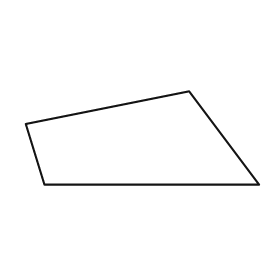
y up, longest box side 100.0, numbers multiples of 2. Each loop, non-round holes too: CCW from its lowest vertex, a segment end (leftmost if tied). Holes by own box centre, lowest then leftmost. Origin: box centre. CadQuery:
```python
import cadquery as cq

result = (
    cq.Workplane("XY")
    .moveTo(-42.0, -20.0)
    .lineTo(50.0, -20.0)
    .lineTo(20.0, 20.0)
    .lineTo(-50.0, 6.0)
    .close()
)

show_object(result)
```